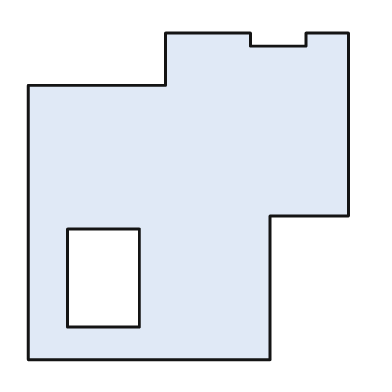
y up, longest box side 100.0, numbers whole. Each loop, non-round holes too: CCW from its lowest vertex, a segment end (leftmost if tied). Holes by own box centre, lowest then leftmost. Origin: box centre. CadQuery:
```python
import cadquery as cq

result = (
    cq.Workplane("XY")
    .moveTo(-49.0, -50.0)
    .lineTo(25.0, -50.0)
    .lineTo(25.0, -6.0)
    .lineTo(49.0, -6.0)
    .lineTo(49.0, 50.0)
    .lineTo(36.0, 50.0)
    .lineTo(36.0, 46.0)
    .lineTo(19.0, 46.0)
    .lineTo(19.0, 50.0)
    .lineTo(-7.0, 50.0)
    .lineTo(-7.0, 34.0)
    .lineTo(-49.0, 34.0)
    .close()
    .moveTo(-37.0, -40.0)
    .lineTo(-15.0, -40.0)
    .lineTo(-15.0, -10.0)
    .lineTo(-37.0, -10.0)
    .close()
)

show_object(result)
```